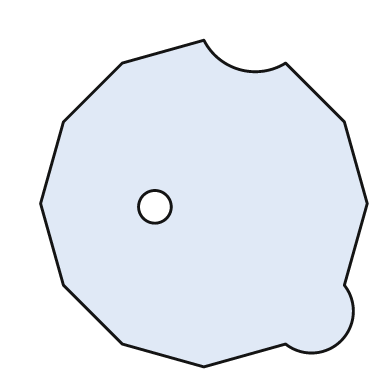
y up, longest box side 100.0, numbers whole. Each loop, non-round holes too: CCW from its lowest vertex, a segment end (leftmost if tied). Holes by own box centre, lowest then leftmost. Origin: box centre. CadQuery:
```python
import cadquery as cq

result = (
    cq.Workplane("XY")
    .moveTo(0.0, -50.0)
    .lineTo(25.0, -43.0)
    .threePointArc((42.0, -42.0), (43.0, -25.0))
    .lineTo(50.0, 0.0)
    .lineTo(43.0, 25.0)
    .lineTo(25.0, 43.0)
    .threePointArc((11.0, 41.0), (0.0, 50.0))
    .lineTo(-25.0, 43.0)
    .lineTo(-43.0, 25.0)
    .lineTo(-50.0, 0.0)
    .lineTo(-43.0, -25.0)
    .lineTo(-25.0, -43.0)
    .close()
    .moveTo(-15.0, -1.0)
    .circle(5.0)
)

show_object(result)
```